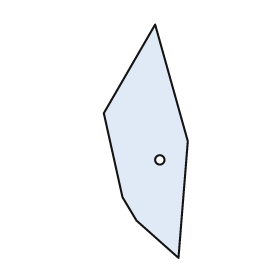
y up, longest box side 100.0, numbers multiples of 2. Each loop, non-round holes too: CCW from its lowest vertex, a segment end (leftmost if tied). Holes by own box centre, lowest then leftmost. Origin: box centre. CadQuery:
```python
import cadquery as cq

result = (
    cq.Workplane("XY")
    .moveTo(14.0, -50.0)
    .lineTo(18.0, 0.0)
    .lineTo(4.0, 50.0)
    .lineTo(-18.0, 12.0)
    .lineTo(-10.0, -24.0)
    .lineTo(-4.0, -34.0)
    .close()
    .moveTo(6.0, -8.0)
    .circle(2.0)
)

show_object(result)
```